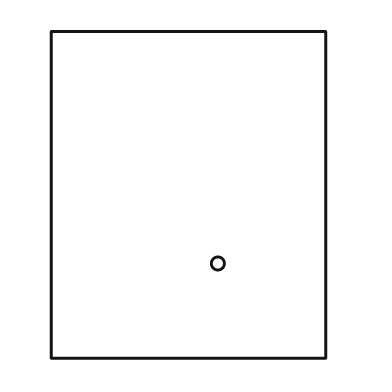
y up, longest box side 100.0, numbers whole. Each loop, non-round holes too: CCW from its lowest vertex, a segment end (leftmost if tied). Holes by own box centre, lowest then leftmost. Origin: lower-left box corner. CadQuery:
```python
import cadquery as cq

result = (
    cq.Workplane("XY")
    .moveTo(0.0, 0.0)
    .lineTo(84.0, 0.0)
    .lineTo(84.0, 100.0)
    .lineTo(0.0, 100.0)
    .close()
    .moveTo(51.0, 29.0)
    .circle(2.0)
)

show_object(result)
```